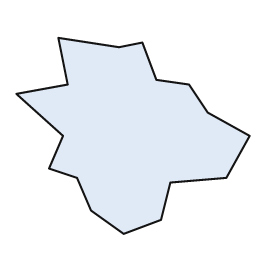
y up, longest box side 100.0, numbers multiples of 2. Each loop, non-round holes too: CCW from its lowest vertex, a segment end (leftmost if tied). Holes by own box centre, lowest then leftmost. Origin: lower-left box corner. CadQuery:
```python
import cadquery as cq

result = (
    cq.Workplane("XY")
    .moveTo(46.0, 0.0)
    .lineTo(62.0, 6.0)
    .lineTo(66.0, 22.0)
    .lineTo(90.0, 24.0)
    .lineTo(100.0, 42.0)
    .lineTo(82.0, 52.0)
    .lineTo(74.0, 64.0)
    .lineTo(60.0, 66.0)
    .lineTo(54.0, 82.0)
    .lineTo(44.0, 80.0)
    .lineTo(18.0, 84.0)
    .lineTo(22.0, 64.0)
    .lineTo(0.0, 60.0)
    .lineTo(20.0, 42.0)
    .lineTo(14.0, 28.0)
    .lineTo(26.0, 24.0)
    .lineTo(32.0, 10.0)
    .close()
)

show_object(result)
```